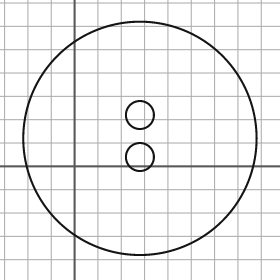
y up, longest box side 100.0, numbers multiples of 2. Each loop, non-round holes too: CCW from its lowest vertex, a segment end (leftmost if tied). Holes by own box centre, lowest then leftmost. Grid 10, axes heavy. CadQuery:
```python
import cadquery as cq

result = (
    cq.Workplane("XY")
    .moveTo(28.0, 12.0)
    .circle(50.0)
    .moveTo(28.0, 4.0)
    .circle(6.0)
    .moveTo(28.0, 22.0)
    .circle(6.0)
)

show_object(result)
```